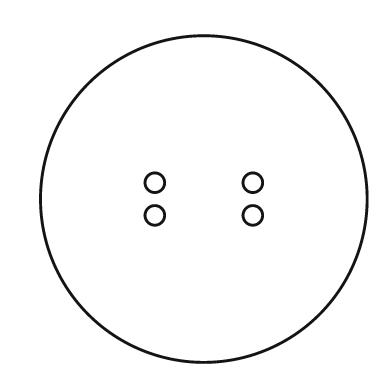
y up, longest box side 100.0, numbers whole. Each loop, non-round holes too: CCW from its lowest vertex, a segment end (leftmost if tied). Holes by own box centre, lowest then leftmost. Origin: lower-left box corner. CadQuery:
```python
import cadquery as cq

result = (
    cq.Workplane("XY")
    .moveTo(50.0, 50.0)
    .circle(50.0)
    .moveTo(35.0, 45.0)
    .circle(3.0)
    .moveTo(65.0, 45.0)
    .circle(3.0)
    .moveTo(35.0, 55.0)
    .circle(3.0)
    .moveTo(65.0, 55.0)
    .circle(3.0)
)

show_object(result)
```